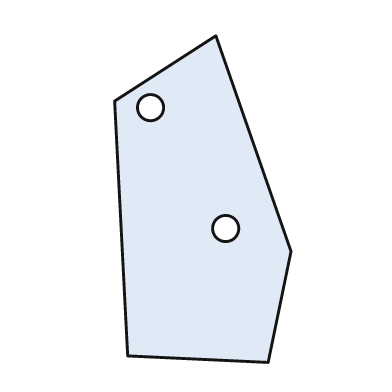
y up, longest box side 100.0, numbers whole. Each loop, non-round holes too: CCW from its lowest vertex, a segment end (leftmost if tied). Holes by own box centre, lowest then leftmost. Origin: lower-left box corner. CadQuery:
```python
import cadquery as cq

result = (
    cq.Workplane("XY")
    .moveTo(47.0, 0.0)
    .lineTo(54.0, 34.0)
    .lineTo(31.0, 100.0)
    .lineTo(0.0, 80.0)
    .lineTo(4.0, 2.0)
    .close()
    .moveTo(34.0, 41.0)
    .circle(4.0)
    .moveTo(11.0, 78.0)
    .circle(4.0)
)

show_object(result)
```